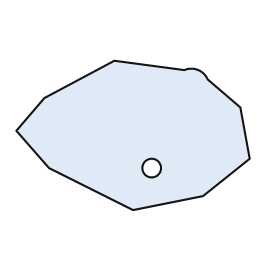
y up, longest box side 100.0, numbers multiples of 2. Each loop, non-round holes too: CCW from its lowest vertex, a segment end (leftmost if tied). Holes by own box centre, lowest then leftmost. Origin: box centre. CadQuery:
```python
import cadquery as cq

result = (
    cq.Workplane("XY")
    .moveTo(0.0, -32.0)
    .lineTo(30.0, -26.0)
    .lineTo(50.0, -10.0)
    .lineTo(46.0, 12.0)
    .lineTo(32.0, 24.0)
    .threePointArc((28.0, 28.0), (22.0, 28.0))
    .lineTo(-8.0, 32.0)
    .lineTo(-38.0, 16.0)
    .lineTo(-50.0, 2.0)
    .lineTo(-36.0, -14.0)
    .close()
    .moveTo(8.0, -14.0)
    .circle(4.0)
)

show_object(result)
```